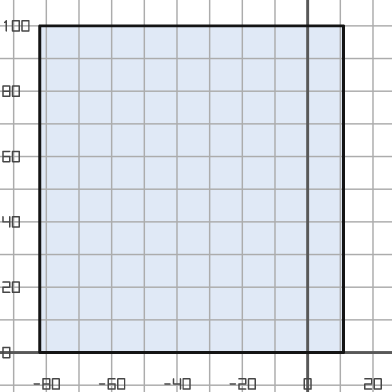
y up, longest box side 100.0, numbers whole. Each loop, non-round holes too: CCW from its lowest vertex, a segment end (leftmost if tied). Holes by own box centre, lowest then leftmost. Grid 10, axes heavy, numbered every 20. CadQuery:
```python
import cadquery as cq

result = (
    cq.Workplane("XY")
    .moveTo(-82.0, 0.0)
    .lineTo(11.0, 0.0)
    .lineTo(11.0, 100.0)
    .lineTo(-82.0, 100.0)
    .close()
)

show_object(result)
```